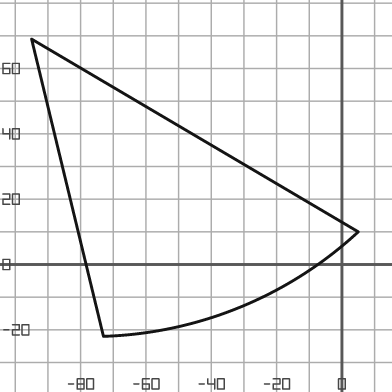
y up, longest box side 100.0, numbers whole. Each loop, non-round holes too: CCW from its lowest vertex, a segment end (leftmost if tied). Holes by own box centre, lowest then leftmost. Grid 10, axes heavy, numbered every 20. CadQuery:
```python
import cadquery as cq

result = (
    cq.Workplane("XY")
    .moveTo(-73.0, -22.0)
    .threePointArc((-31.0, -13.0), (5.0, 10.0))
    .lineTo(-95.0, 69.0)
    .close()
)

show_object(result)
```